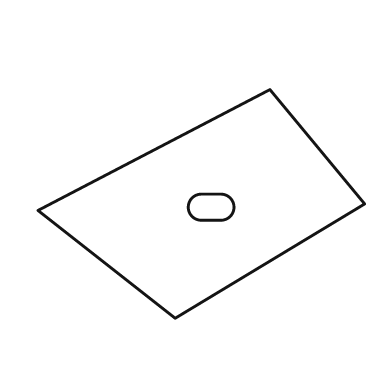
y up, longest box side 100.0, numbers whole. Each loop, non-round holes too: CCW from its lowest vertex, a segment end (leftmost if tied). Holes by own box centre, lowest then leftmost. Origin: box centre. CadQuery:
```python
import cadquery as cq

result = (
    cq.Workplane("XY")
    .moveTo(-8.0, -35.0)
    .lineTo(50.0, 0.0)
    .lineTo(21.0, 35.0)
    .lineTo(-50.0, -2.0)
    .close()
    .moveTo(0.0, -5.0)
    .lineTo(6.0, -5.0)
    .threePointArc((10.0, -1.0), (6.0, 3.0))
    .lineTo(0.0, 3.0)
    .threePointArc((-4.0, -1.0), (0.0, -5.0))
    .close()
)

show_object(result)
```